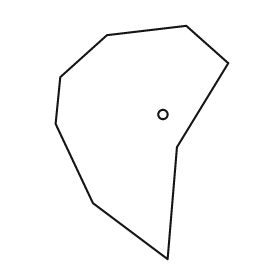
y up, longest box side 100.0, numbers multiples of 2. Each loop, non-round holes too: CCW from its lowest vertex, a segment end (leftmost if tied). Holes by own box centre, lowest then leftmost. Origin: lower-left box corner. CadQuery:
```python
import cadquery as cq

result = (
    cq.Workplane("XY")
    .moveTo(48.0, 0.0)
    .lineTo(52.0, 48.0)
    .lineTo(74.0, 84.0)
    .lineTo(56.0, 100.0)
    .lineTo(22.0, 96.0)
    .lineTo(2.0, 78.0)
    .lineTo(0.0, 58.0)
    .lineTo(16.0, 24.0)
    .close()
    .moveTo(46.0, 62.0)
    .circle(2.0)
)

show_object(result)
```